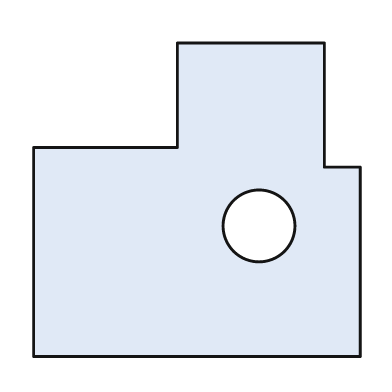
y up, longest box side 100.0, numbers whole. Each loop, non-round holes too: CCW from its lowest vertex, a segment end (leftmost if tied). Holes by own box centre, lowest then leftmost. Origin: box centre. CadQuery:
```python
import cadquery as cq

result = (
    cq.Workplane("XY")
    .moveTo(-50.0, -48.0)
    .lineTo(50.0, -48.0)
    .lineTo(50.0, 10.0)
    .lineTo(39.0, 10.0)
    .lineTo(39.0, 48.0)
    .lineTo(-6.0, 48.0)
    .lineTo(-6.0, 16.0)
    .lineTo(-50.0, 16.0)
    .close()
    .moveTo(19.0, -8.0)
    .circle(11.0)
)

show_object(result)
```